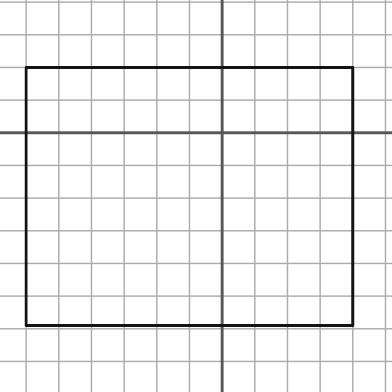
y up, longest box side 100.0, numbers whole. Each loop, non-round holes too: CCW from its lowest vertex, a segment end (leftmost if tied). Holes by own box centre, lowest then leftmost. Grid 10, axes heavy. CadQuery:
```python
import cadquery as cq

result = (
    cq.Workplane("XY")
    .moveTo(-60.0, -59.0)
    .lineTo(40.0, -59.0)
    .lineTo(40.0, 20.0)
    .lineTo(-60.0, 20.0)
    .close()
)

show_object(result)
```